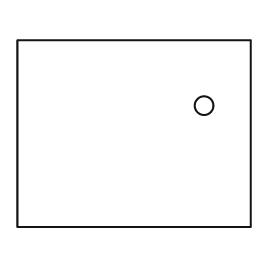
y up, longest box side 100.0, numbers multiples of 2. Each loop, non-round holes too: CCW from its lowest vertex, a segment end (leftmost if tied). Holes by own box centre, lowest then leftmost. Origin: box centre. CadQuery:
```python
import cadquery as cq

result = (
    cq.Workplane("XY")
    .moveTo(-50.0, -40.0)
    .lineTo(50.0, -40.0)
    .lineTo(50.0, 40.0)
    .lineTo(-50.0, 40.0)
    .close()
    .moveTo(30.0, 12.0)
    .circle(4.0)
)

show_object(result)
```